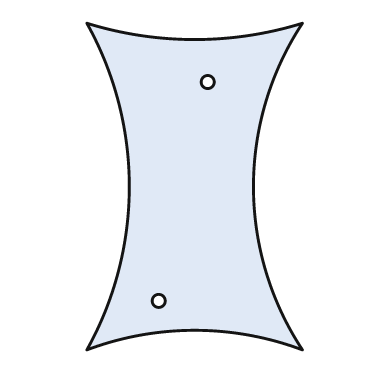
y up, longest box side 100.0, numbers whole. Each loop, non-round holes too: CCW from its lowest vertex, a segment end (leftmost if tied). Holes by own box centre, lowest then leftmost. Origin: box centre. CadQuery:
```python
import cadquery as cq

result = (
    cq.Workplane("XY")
    .moveTo(-33.0, -50.0)
    .threePointArc((0.0, -44.0), (33.0, -50.0))
    .threePointArc((18.0, 0.0), (33.0, 50.0))
    .threePointArc((0.0, 45.0), (-33.0, 50.0))
    .threePointArc((-20.0, 0.0), (-33.0, -50.0))
    .close()
    .moveTo(-11.0, -35.0)
    .circle(2.0)
    .moveTo(4.0, 32.0)
    .circle(2.0)
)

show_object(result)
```